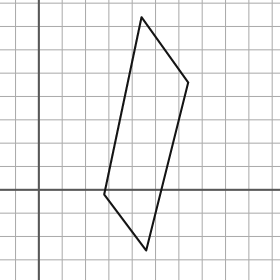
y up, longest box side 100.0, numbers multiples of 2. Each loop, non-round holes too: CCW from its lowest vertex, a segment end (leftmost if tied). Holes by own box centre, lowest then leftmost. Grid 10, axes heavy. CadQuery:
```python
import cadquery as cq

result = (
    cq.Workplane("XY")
    .moveTo(46.0, -26.0)
    .lineTo(64.0, 46.0)
    .lineTo(44.0, 74.0)
    .lineTo(28.0, -2.0)
    .close()
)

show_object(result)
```